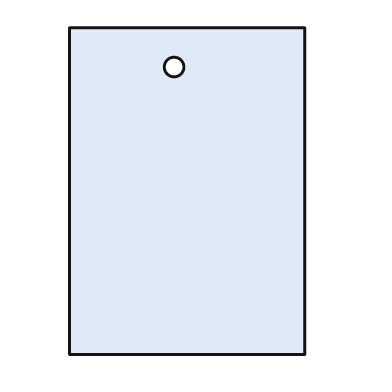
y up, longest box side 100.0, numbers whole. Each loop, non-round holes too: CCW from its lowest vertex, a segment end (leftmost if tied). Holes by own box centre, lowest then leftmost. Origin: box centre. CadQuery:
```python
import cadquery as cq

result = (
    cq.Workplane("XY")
    .moveTo(-36.0, -50.0)
    .lineTo(36.0, -50.0)
    .lineTo(36.0, 50.0)
    .lineTo(-36.0, 50.0)
    .close()
    .moveTo(-4.0, 38.0)
    .circle(3.0)
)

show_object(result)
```